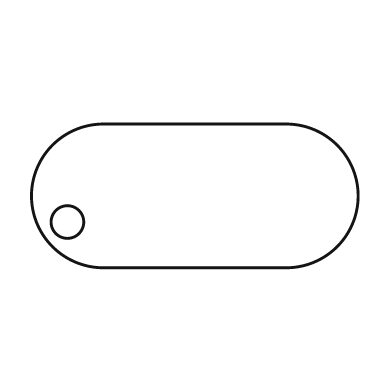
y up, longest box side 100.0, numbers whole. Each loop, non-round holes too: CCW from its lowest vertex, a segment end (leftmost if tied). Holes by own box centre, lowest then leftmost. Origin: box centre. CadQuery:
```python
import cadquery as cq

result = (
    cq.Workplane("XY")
    .moveTo(-28.0, -22.0)
    .lineTo(28.0, -22.0)
    .threePointArc((50.0, 0.0), (28.0, 22.0))
    .lineTo(-28.0, 22.0)
    .threePointArc((-50.0, 0.0), (-28.0, -22.0))
    .close()
    .moveTo(-39.0, -8.0)
    .circle(5.0)
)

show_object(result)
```